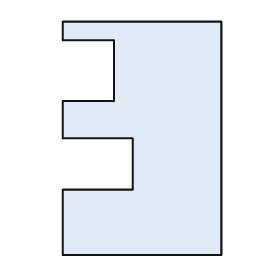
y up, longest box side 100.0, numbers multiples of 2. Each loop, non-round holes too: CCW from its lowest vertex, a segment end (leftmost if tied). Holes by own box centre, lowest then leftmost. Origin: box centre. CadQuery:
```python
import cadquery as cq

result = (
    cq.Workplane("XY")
    .moveTo(-34.0, -50.0)
    .lineTo(34.0, -50.0)
    .lineTo(34.0, 50.0)
    .lineTo(-34.0, 50.0)
    .lineTo(-34.0, 42.0)
    .lineTo(-12.0, 42.0)
    .lineTo(-12.0, 16.0)
    .lineTo(-34.0, 16.0)
    .lineTo(-34.0, 0.0)
    .lineTo(-4.0, 0.0)
    .lineTo(-4.0, -22.0)
    .lineTo(-34.0, -22.0)
    .close()
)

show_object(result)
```